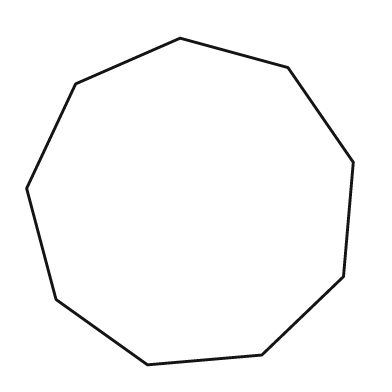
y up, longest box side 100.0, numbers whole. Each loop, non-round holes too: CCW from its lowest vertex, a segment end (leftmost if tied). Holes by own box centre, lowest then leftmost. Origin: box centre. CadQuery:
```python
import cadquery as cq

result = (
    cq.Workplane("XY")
    .moveTo(-13.0, -50.0)
    .lineTo(22.0, -47.0)
    .lineTo(47.0, -23.0)
    .lineTo(50.0, 12.0)
    .lineTo(30.0, 41.0)
    .lineTo(-3.0, 50.0)
    .lineTo(-35.0, 36.0)
    .lineTo(-50.0, 4.0)
    .lineTo(-41.0, -30.0)
    .close()
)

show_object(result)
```